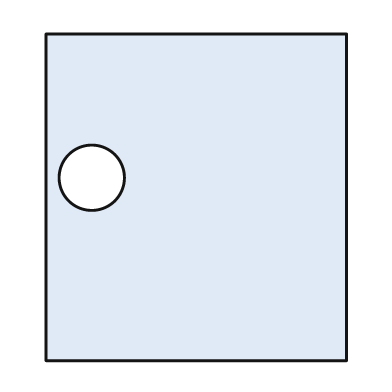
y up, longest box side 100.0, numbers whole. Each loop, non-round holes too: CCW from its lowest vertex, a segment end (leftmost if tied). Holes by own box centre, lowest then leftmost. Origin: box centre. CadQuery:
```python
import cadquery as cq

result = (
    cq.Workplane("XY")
    .moveTo(-46.0, -50.0)
    .lineTo(46.0, -50.0)
    .lineTo(46.0, 50.0)
    .lineTo(-46.0, 50.0)
    .close()
    .moveTo(-32.0, 6.0)
    .circle(10.0)
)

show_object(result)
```